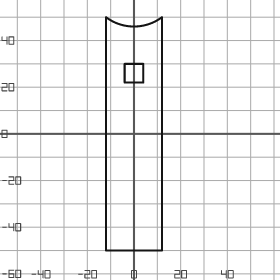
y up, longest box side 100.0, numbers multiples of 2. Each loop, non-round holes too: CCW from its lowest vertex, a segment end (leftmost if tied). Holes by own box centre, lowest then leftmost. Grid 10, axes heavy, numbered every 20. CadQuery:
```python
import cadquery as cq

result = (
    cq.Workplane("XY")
    .moveTo(-12.0, -50.0)
    .lineTo(12.0, -50.0)
    .lineTo(12.0, 50.0)
    .threePointArc((0.0, 46.0), (-12.0, 50.0))
    .close()
    .moveTo(-4.0, 22.0)
    .lineTo(4.0, 22.0)
    .lineTo(4.0, 30.0)
    .lineTo(-4.0, 30.0)
    .close()
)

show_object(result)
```